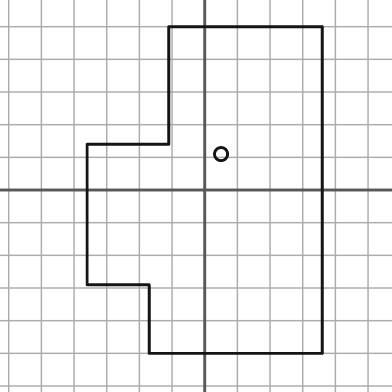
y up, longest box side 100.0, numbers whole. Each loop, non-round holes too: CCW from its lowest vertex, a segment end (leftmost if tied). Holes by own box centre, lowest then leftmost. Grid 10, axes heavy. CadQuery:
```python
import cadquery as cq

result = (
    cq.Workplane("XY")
    .moveTo(-17.0, -50.0)
    .lineTo(36.0, -50.0)
    .lineTo(36.0, 50.0)
    .lineTo(-11.0, 50.0)
    .lineTo(-11.0, 14.0)
    .lineTo(-36.0, 14.0)
    .lineTo(-36.0, -29.0)
    .lineTo(-17.0, -29.0)
    .close()
    .moveTo(5.0, 11.0)
    .circle(2.0)
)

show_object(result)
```